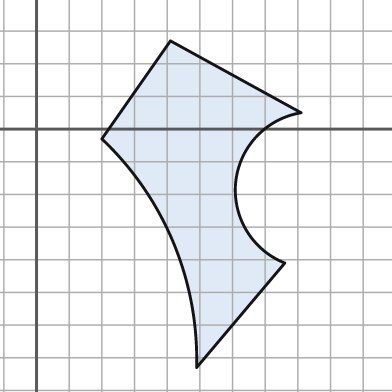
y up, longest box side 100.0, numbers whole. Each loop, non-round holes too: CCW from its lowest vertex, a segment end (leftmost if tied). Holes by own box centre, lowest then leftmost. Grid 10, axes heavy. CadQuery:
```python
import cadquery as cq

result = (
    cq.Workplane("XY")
    .moveTo(49.0, -73.0)
    .lineTo(76.0, -41.0)
    .threePointArc((61.0, -16.0), (81.0, 5.0))
    .lineTo(41.0, 27.0)
    .lineTo(20.0, -3.0)
    .threePointArc((42.0, -35.0), (49.0, -73.0))
    .close()
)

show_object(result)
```